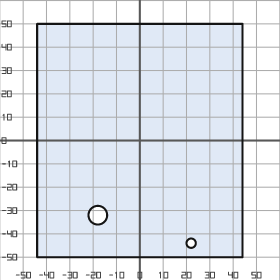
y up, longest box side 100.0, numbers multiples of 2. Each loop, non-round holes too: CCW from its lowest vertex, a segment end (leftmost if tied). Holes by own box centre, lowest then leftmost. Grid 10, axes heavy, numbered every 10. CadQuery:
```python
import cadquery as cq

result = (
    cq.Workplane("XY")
    .moveTo(-44.0, -50.0)
    .lineTo(44.0, -50.0)
    .lineTo(44.0, 50.0)
    .lineTo(-44.0, 50.0)
    .close()
    .moveTo(22.0, -44.0)
    .circle(2.0)
    .moveTo(-18.0, -32.0)
    .circle(4.0)
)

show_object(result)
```